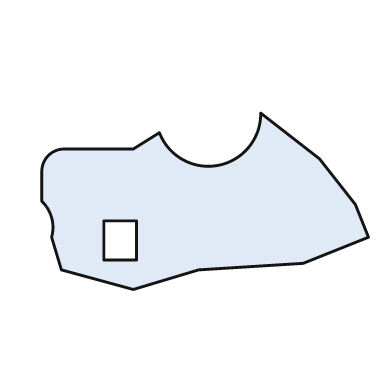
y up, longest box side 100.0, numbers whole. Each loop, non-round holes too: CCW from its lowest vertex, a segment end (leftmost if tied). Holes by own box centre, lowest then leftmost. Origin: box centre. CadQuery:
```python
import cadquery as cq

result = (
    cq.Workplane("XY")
    .moveTo(-22.0, -27.0)
    .lineTo(-2.0, -21.0)
    .lineTo(30.0, -19.0)
    .lineTo(50.0, -11.0)
    .lineTo(46.0, -1.0)
    .lineTo(35.0, 13.0)
    .lineTo(17.0, 27.0)
    .threePointArc((4.0, 11.0), (-14.0, 21.0))
    .lineTo(-22.0, 16.0)
    .lineTo(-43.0, 16.0)
    .threePointArc((-48.0, 14.0), (-50.0, 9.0))
    .lineTo(-50.0, 0.0)
    .threePointArc((-47.0, -5.0), (-47.0, -11.0))
    .lineTo(-44.0, -21.0)
    .close()
    .moveTo(-31.0, -18.0)
    .lineTo(-21.0, -18.0)
    .lineTo(-21.0, -6.0)
    .lineTo(-31.0, -6.0)
    .close()
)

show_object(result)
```